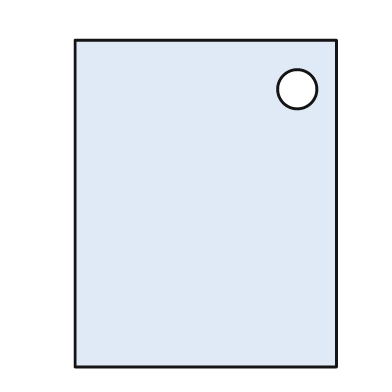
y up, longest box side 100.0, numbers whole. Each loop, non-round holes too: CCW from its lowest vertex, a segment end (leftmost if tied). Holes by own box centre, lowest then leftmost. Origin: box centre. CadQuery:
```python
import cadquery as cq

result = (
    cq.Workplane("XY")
    .moveTo(-40.0, -50.0)
    .lineTo(40.0, -50.0)
    .lineTo(40.0, 50.0)
    .lineTo(-40.0, 50.0)
    .close()
    .moveTo(28.0, 35.0)
    .circle(6.0)
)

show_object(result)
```